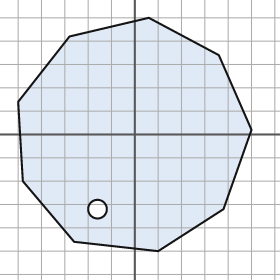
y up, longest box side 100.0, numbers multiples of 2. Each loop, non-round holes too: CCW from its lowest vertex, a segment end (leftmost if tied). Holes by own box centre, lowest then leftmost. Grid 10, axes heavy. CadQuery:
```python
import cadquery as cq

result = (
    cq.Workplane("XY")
    .moveTo(10.0, -50.0)
    .lineTo(38.0, -32.0)
    .lineTo(50.0, 2.0)
    .lineTo(36.0, 34.0)
    .lineTo(6.0, 50.0)
    .lineTo(-28.0, 42.0)
    .lineTo(-50.0, 14.0)
    .lineTo(-48.0, -20.0)
    .lineTo(-26.0, -46.0)
    .close()
    .moveTo(-16.0, -32.0)
    .circle(4.0)
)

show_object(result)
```